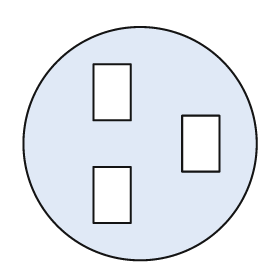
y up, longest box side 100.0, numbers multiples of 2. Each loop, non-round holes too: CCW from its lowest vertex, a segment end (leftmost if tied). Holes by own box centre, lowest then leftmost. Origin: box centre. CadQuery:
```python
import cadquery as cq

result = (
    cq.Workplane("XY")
    .moveTo(0.0, 0.0)
    .circle(50.0)
    .moveTo(-20.0, -34.0)
    .lineTo(-4.0, -34.0)
    .lineTo(-4.0, -10.0)
    .lineTo(-20.0, -10.0)
    .close()
    .moveTo(18.0, -12.0)
    .lineTo(34.0, -12.0)
    .lineTo(34.0, 12.0)
    .lineTo(18.0, 12.0)
    .close()
    .moveTo(-20.0, 10.0)
    .lineTo(-4.0, 10.0)
    .lineTo(-4.0, 34.0)
    .lineTo(-20.0, 34.0)
    .close()
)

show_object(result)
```